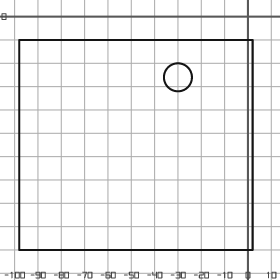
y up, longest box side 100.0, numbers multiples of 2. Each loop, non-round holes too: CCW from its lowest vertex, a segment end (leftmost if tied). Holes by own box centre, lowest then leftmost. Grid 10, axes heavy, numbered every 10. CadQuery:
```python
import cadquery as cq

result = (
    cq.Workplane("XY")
    .moveTo(-98.0, -100.0)
    .lineTo(2.0, -100.0)
    .lineTo(2.0, -10.0)
    .lineTo(-98.0, -10.0)
    .close()
    .moveTo(-30.0, -26.0)
    .circle(6.0)
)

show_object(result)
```